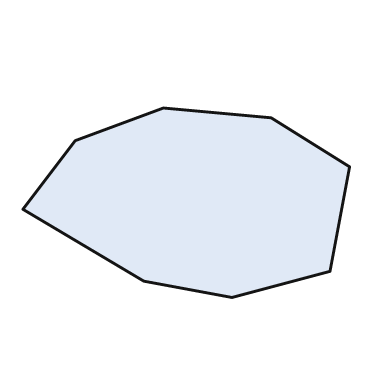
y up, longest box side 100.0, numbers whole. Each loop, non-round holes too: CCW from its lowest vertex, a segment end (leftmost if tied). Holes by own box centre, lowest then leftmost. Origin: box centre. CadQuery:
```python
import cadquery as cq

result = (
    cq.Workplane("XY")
    .moveTo(14.0, -29.0)
    .lineTo(44.0, -21.0)
    .lineTo(50.0, 11.0)
    .lineTo(26.0, 26.0)
    .lineTo(-7.0, 29.0)
    .lineTo(-34.0, 19.0)
    .lineTo(-50.0, -2.0)
    .lineTo(-13.0, -24.0)
    .close()
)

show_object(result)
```